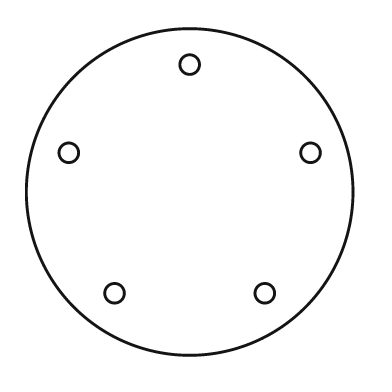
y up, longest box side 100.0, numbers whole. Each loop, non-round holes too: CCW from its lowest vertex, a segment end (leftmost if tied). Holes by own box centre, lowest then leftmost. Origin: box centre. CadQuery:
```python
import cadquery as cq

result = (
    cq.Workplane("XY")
    .moveTo(0.0, 0.0)
    .circle(50.0)
    .moveTo(-23.0, -31.0)
    .circle(3.0)
    .moveTo(23.0, -31.0)
    .circle(3.0)
    .moveTo(-37.0, 12.0)
    .circle(3.0)
    .moveTo(37.0, 12.0)
    .circle(3.0)
    .moveTo(0.0, 39.0)
    .circle(3.0)
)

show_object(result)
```